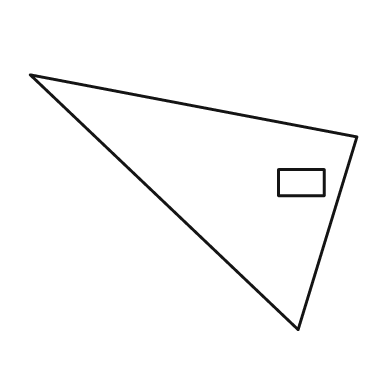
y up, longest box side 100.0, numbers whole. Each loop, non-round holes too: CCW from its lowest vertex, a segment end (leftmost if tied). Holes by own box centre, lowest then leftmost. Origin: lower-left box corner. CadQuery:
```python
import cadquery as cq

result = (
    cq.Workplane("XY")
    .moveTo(82.0, 0.0)
    .lineTo(100.0, 59.0)
    .lineTo(0.0, 78.0)
    .close()
    .moveTo(76.0, 41.0)
    .lineTo(90.0, 41.0)
    .lineTo(90.0, 49.0)
    .lineTo(76.0, 49.0)
    .close()
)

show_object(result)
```